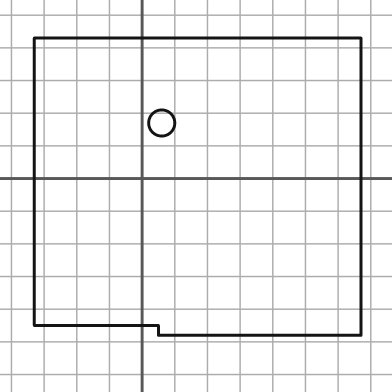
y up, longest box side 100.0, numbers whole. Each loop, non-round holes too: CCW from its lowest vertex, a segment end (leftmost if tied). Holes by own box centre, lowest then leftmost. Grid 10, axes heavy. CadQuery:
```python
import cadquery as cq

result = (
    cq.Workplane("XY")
    .moveTo(5.0, -48.0)
    .lineTo(67.0, -48.0)
    .lineTo(67.0, 43.0)
    .lineTo(-33.0, 43.0)
    .lineTo(-33.0, -45.0)
    .lineTo(5.0, -45.0)
    .close()
    .moveTo(6.0, 17.0)
    .circle(4.0)
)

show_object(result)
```